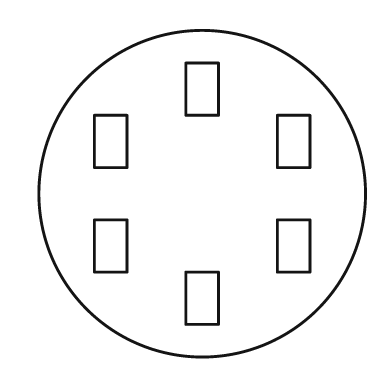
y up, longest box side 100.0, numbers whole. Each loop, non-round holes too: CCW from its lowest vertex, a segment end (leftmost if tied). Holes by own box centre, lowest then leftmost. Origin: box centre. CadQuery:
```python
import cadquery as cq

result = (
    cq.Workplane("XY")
    .moveTo(0.0, 0.0)
    .circle(50.0)
    .moveTo(-5.0, -40.0)
    .lineTo(5.0, -40.0)
    .lineTo(5.0, -24.0)
    .lineTo(-5.0, -24.0)
    .close()
    .moveTo(-33.0, -24.0)
    .lineTo(-23.0, -24.0)
    .lineTo(-23.0, -8.0)
    .lineTo(-33.0, -8.0)
    .close()
    .moveTo(23.0, -24.0)
    .lineTo(33.0, -24.0)
    .lineTo(33.0, -8.0)
    .lineTo(23.0, -8.0)
    .close()
    .moveTo(-33.0, 8.0)
    .lineTo(-23.0, 8.0)
    .lineTo(-23.0, 24.0)
    .lineTo(-33.0, 24.0)
    .close()
    .moveTo(23.0, 8.0)
    .lineTo(33.0, 8.0)
    .lineTo(33.0, 24.0)
    .lineTo(23.0, 24.0)
    .close()
    .moveTo(-5.0, 24.0)
    .lineTo(5.0, 24.0)
    .lineTo(5.0, 40.0)
    .lineTo(-5.0, 40.0)
    .close()
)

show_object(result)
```